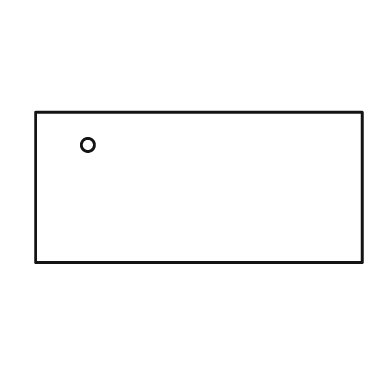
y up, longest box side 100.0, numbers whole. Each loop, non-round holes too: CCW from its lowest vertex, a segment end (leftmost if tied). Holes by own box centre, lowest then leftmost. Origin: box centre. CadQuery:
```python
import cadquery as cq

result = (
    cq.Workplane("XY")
    .moveTo(-50.0, -23.0)
    .lineTo(50.0, -23.0)
    .lineTo(50.0, 23.0)
    .lineTo(-50.0, 23.0)
    .close()
    .moveTo(-34.0, 13.0)
    .circle(2.0)
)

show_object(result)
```